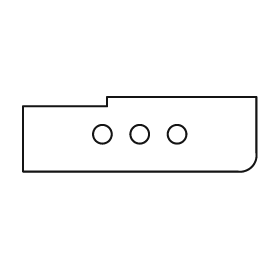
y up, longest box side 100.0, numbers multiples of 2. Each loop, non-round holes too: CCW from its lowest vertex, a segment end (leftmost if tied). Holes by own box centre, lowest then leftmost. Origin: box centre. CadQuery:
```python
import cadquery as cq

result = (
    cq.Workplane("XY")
    .moveTo(-50.0, -16.0)
    .lineTo(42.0, -16.0)
    .threePointArc((48.0, -14.0), (50.0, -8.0))
    .lineTo(50.0, 16.0)
    .lineTo(-14.0, 16.0)
    .lineTo(-14.0, 12.0)
    .lineTo(-50.0, 12.0)
    .close()
    .moveTo(-16.0, 0.0)
    .circle(4.0)
    .moveTo(0.0, 0.0)
    .circle(4.0)
    .moveTo(16.0, 0.0)
    .circle(4.0)
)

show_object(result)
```